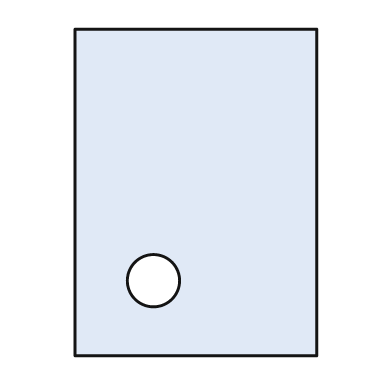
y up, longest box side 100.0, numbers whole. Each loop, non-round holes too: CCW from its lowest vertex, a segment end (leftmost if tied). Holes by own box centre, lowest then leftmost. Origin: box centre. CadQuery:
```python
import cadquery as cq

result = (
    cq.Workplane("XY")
    .moveTo(-37.0, -50.0)
    .lineTo(37.0, -50.0)
    .lineTo(37.0, 50.0)
    .lineTo(-37.0, 50.0)
    .close()
    .moveTo(-13.0, -27.0)
    .circle(8.0)
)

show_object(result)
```